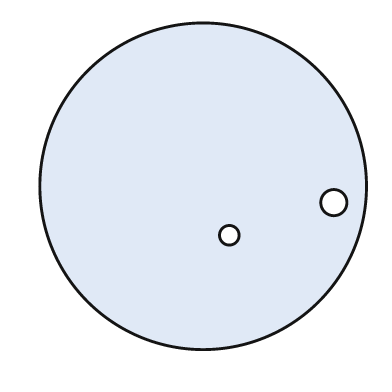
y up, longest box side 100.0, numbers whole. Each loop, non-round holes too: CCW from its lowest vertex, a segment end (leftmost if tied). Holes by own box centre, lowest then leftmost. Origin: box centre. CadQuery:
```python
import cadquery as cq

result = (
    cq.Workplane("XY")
    .moveTo(0.0, 0.0)
    .circle(50.0)
    .moveTo(8.0, -15.0)
    .circle(3.0)
    .moveTo(40.0, -5.0)
    .circle(4.0)
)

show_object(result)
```